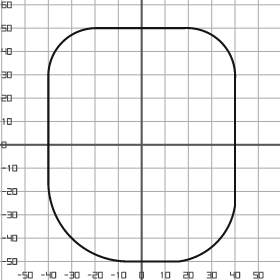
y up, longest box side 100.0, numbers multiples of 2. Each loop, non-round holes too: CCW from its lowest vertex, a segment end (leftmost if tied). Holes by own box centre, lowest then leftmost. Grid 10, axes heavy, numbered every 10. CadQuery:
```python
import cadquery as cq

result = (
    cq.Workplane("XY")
    .moveTo(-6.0, -50.0)
    .lineTo(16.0, -50.0)
    .threePointArc((32.0, -42.0), (40.0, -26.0))
    .lineTo(40.0, 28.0)
    .threePointArc((34.0, 44.0), (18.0, 50.0))
    .lineTo(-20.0, 50.0)
    .threePointArc((-34.0, 44.0), (-40.0, 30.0))
    .lineTo(-40.0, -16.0)
    .threePointArc((-30.0, -40.0), (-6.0, -50.0))
    .close()
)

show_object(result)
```